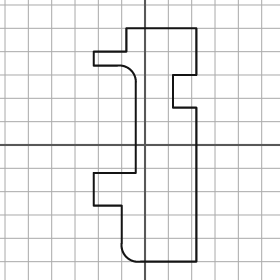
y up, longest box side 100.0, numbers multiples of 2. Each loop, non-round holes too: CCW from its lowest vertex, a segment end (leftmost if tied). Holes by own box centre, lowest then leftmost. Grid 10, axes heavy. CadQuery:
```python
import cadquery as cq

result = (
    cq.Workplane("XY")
    .moveTo(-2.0, -50.0)
    .lineTo(22.0, -50.0)
    .lineTo(22.0, 16.0)
    .lineTo(12.0, 16.0)
    .lineTo(12.0, 30.0)
    .lineTo(22.0, 30.0)
    .lineTo(22.0, 50.0)
    .lineTo(-8.0, 50.0)
    .lineTo(-8.0, 40.0)
    .lineTo(-22.0, 40.0)
    .lineTo(-22.0, 34.0)
    .lineTo(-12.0, 34.0)
    .threePointArc((-6.0, 32.0), (-4.0, 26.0))
    .lineTo(-4.0, -12.0)
    .lineTo(-22.0, -12.0)
    .lineTo(-22.0, -26.0)
    .lineTo(-10.0, -26.0)
    .lineTo(-10.0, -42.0)
    .threePointArc((-8.0, -48.0), (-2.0, -50.0))
    .close()
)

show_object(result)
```